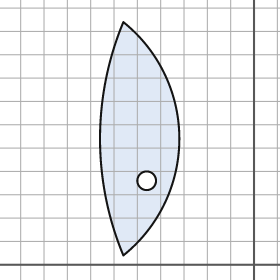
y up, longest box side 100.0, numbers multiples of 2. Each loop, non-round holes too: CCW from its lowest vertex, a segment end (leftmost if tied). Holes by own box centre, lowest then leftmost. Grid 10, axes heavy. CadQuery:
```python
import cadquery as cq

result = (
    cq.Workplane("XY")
    .moveTo(-56.0, 4.0)
    .threePointArc((-32.0, 54.0), (-56.0, 104.0))
    .threePointArc((-66.0, 54.0), (-56.0, 4.0))
    .close()
    .moveTo(-46.0, 36.0)
    .circle(4.0)
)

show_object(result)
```